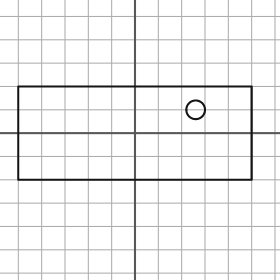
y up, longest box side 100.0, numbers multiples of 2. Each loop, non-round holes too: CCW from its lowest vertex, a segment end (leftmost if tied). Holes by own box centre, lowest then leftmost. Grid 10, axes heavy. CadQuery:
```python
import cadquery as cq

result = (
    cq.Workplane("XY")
    .moveTo(-50.0, -20.0)
    .lineTo(50.0, -20.0)
    .lineTo(50.0, 20.0)
    .lineTo(-50.0, 20.0)
    .close()
    .moveTo(26.0, 10.0)
    .circle(4.0)
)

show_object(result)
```